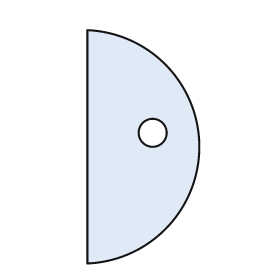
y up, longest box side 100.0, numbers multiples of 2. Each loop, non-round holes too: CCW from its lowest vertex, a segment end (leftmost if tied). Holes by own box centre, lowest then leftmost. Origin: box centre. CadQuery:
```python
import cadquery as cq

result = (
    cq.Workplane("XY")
    .moveTo(-24.0, -50.0)
    .threePointArc((24.0, 0.0), (-24.0, 50.0))
    .close()
    .moveTo(4.0, 6.0)
    .circle(6.0)
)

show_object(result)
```